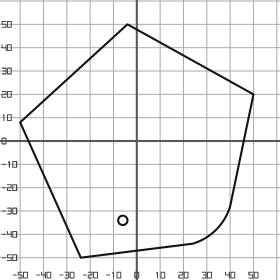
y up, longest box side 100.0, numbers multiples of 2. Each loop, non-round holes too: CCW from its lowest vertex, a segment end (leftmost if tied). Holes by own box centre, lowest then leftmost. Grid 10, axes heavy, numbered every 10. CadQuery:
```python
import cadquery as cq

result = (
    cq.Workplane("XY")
    .moveTo(-24.0, -50.0)
    .lineTo(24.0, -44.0)
    .threePointArc((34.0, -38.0), (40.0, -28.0))
    .lineTo(50.0, 20.0)
    .lineTo(-4.0, 50.0)
    .lineTo(-50.0, 8.0)
    .close()
    .moveTo(-6.0, -34.0)
    .circle(2.0)
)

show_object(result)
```